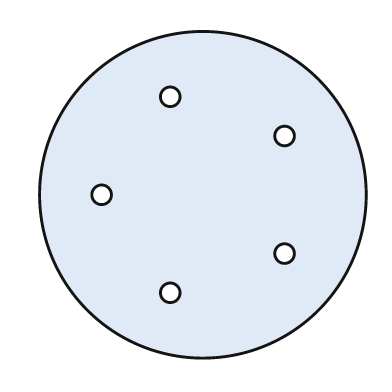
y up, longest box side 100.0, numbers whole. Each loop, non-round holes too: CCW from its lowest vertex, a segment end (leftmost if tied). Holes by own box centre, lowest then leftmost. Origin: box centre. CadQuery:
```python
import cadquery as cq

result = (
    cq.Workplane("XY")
    .moveTo(0.0, 0.0)
    .circle(50.0)
    .moveTo(-10.0, -30.0)
    .circle(3.0)
    .moveTo(25.0, -18.0)
    .circle(3.0)
    .moveTo(-31.0, 0.0)
    .circle(3.0)
    .moveTo(25.0, 18.0)
    .circle(3.0)
    .moveTo(-10.0, 30.0)
    .circle(3.0)
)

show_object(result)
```